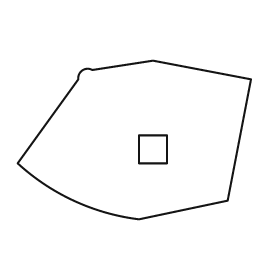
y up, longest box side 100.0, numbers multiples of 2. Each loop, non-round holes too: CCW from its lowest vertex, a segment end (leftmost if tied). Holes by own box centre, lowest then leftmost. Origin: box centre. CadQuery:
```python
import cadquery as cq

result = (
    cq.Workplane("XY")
    .moveTo(2.0, -34.0)
    .lineTo(40.0, -26.0)
    .lineTo(50.0, 26.0)
    .lineTo(8.0, 34.0)
    .lineTo(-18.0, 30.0)
    .threePointArc((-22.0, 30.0), (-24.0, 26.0))
    .lineTo(-50.0, -10.0)
    .threePointArc((-26.0, -26.0), (2.0, -34.0))
    .close()
    .moveTo(2.0, -10.0)
    .lineTo(14.0, -10.0)
    .lineTo(14.0, 2.0)
    .lineTo(2.0, 2.0)
    .close()
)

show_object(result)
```